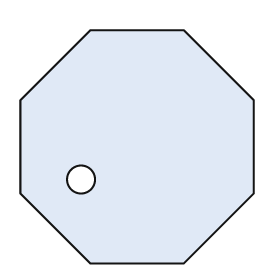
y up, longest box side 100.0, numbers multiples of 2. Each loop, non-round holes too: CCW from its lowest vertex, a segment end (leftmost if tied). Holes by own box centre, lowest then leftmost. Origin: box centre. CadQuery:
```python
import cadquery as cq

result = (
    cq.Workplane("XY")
    .moveTo(-20.0, -50.0)
    .lineTo(20.0, -50.0)
    .lineTo(50.0, -20.0)
    .lineTo(50.0, 20.0)
    .lineTo(20.0, 50.0)
    .lineTo(-20.0, 50.0)
    .lineTo(-50.0, 20.0)
    .lineTo(-50.0, -20.0)
    .close()
    .moveTo(-24.0, -14.0)
    .circle(6.0)
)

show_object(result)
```